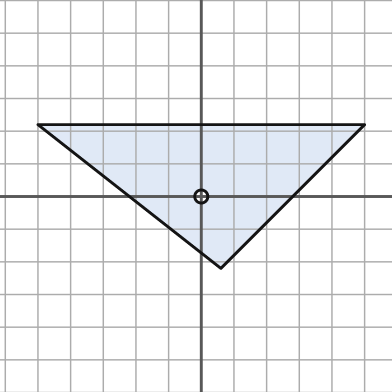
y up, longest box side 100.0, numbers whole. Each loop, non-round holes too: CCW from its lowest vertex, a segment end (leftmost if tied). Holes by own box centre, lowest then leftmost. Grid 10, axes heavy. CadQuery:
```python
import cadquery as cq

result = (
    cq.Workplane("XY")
    .moveTo(6.0, -22.0)
    .lineTo(50.0, 22.0)
    .lineTo(-50.0, 22.0)
    .close()
    .moveTo(0.0, 0.0)
    .circle(2.0)
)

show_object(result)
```